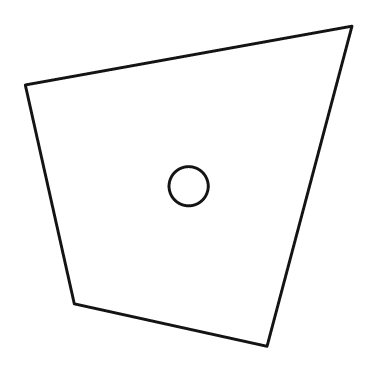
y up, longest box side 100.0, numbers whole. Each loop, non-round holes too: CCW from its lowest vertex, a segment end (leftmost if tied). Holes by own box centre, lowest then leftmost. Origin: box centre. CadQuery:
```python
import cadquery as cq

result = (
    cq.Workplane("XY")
    .moveTo(24.0, -49.0)
    .lineTo(50.0, 49.0)
    .lineTo(-50.0, 31.0)
    .lineTo(-35.0, -36.0)
    .close()
    .moveTo(0.0, 0.0)
    .circle(6.0)
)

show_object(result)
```